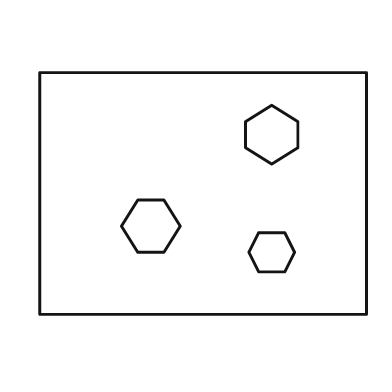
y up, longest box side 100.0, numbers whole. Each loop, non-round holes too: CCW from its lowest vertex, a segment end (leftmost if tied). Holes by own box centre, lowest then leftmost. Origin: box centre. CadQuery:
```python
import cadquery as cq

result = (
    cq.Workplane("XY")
    .moveTo(-50.0, -37.0)
    .lineTo(50.0, -37.0)
    .lineTo(50.0, 37.0)
    .lineTo(-50.0, 37.0)
    .close()
    .moveTo(17.0, -24.0)
    .lineTo(25.0, -24.0)
    .lineTo(28.0, -18.0)
    .lineTo(25.0, -12.0)
    .lineTo(17.0, -12.0)
    .lineTo(14.0, -18.0)
    .close()
    .moveTo(-20.0, -18.0)
    .lineTo(-12.0, -18.0)
    .lineTo(-7.0, -10.0)
    .lineTo(-12.0, -2.0)
    .lineTo(-20.0, -2.0)
    .lineTo(-25.0, -10.0)
    .close()
    .moveTo(21.0, 9.0)
    .lineTo(29.0, 14.0)
    .lineTo(29.0, 22.0)
    .lineTo(21.0, 27.0)
    .lineTo(13.0, 22.0)
    .lineTo(13.0, 14.0)
    .close()
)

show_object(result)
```